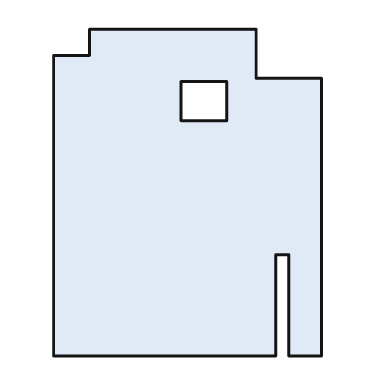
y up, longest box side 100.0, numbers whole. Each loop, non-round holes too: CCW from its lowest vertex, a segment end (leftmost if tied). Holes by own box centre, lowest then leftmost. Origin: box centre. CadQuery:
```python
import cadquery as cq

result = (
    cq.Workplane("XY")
    .moveTo(-41.0, -50.0)
    .lineTo(27.0, -50.0)
    .lineTo(27.0, -19.0)
    .lineTo(31.0, -19.0)
    .lineTo(31.0, -50.0)
    .lineTo(41.0, -50.0)
    .lineTo(41.0, 35.0)
    .lineTo(21.0, 35.0)
    .lineTo(21.0, 50.0)
    .lineTo(-30.0, 50.0)
    .lineTo(-30.0, 42.0)
    .lineTo(-41.0, 42.0)
    .close()
    .moveTo(-2.0, 22.0)
    .lineTo(12.0, 22.0)
    .lineTo(12.0, 34.0)
    .lineTo(-2.0, 34.0)
    .close()
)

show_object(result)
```